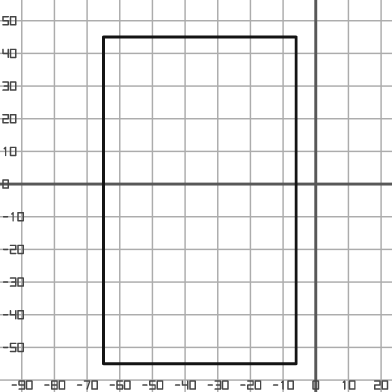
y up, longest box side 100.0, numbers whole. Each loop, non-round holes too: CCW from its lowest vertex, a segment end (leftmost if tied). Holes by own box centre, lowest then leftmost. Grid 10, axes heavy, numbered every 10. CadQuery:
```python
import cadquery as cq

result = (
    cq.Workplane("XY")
    .moveTo(-65.0, -55.0)
    .lineTo(-6.0, -55.0)
    .lineTo(-6.0, 45.0)
    .lineTo(-65.0, 45.0)
    .close()
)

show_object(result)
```